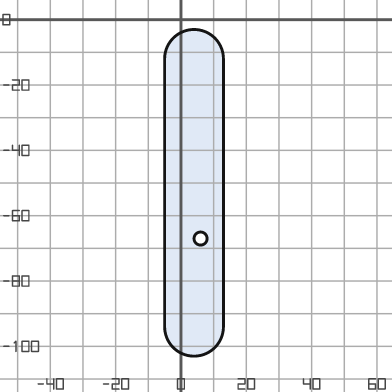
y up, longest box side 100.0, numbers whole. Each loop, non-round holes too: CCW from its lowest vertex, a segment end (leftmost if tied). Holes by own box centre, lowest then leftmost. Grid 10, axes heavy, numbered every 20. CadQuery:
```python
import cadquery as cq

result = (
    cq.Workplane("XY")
    .moveTo(-5.0, -94.0)
    .threePointArc((4.0, -103.0), (13.0, -94.0))
    .lineTo(13.0, -12.0)
    .threePointArc((4.0, -3.0), (-5.0, -12.0))
    .close()
    .moveTo(6.0, -67.0)
    .circle(2.0)
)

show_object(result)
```